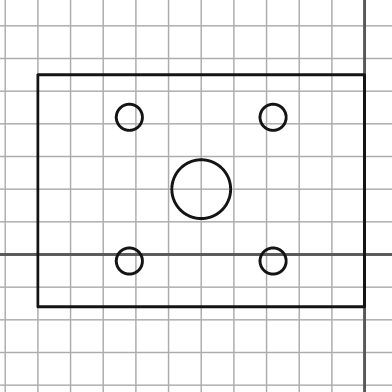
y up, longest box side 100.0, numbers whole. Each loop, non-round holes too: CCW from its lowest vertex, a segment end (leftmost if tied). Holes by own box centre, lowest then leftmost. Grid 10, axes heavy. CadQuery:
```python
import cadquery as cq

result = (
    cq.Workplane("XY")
    .moveTo(-100.0, -16.0)
    .lineTo(0.0, -16.0)
    .lineTo(0.0, 55.0)
    .lineTo(-100.0, 55.0)
    .close()
    .moveTo(-72.0, -2.0)
    .circle(4.0)
    .moveTo(-28.0, -2.0)
    .circle(4.0)
    .moveTo(-50.0, 20.0)
    .circle(9.0)
    .moveTo(-72.0, 42.0)
    .circle(4.0)
    .moveTo(-28.0, 42.0)
    .circle(4.0)
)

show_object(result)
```